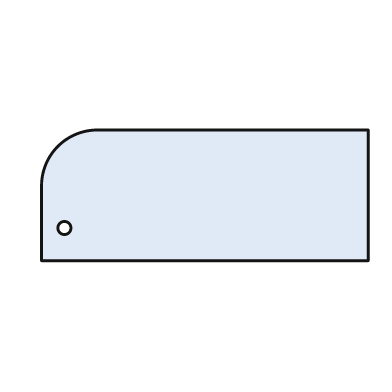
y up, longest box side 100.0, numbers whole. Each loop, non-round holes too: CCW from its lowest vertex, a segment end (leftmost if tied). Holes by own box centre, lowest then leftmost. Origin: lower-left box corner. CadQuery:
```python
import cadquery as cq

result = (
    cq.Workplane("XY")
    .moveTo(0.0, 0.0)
    .lineTo(100.0, 0.0)
    .lineTo(100.0, 40.0)
    .lineTo(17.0, 40.0)
    .threePointArc((5.0, 35.0), (0.0, 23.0))
    .close()
    .moveTo(7.0, 10.0)
    .circle(2.0)
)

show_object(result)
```